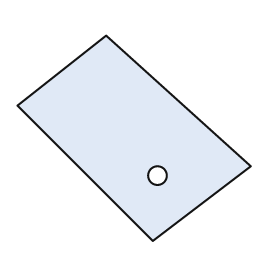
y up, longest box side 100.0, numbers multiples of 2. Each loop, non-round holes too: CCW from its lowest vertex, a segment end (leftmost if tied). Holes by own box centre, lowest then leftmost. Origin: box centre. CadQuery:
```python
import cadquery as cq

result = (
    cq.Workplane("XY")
    .moveTo(8.0, -44.0)
    .lineTo(50.0, -12.0)
    .lineTo(-12.0, 44.0)
    .lineTo(-50.0, 14.0)
    .close()
    .moveTo(10.0, -16.0)
    .circle(4.0)
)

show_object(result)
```